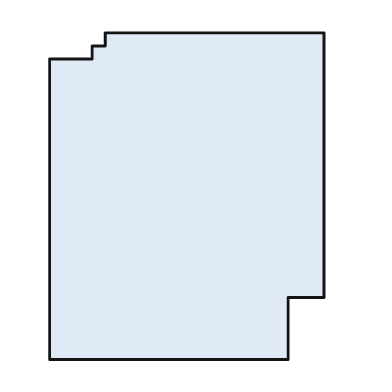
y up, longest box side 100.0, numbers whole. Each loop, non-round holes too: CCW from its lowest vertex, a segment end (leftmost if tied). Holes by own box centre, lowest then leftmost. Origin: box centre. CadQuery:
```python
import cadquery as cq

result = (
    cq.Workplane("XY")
    .moveTo(-42.0, -50.0)
    .lineTo(31.0, -50.0)
    .lineTo(31.0, -31.0)
    .lineTo(42.0, -31.0)
    .lineTo(42.0, 50.0)
    .lineTo(-25.0, 50.0)
    .lineTo(-25.0, 46.0)
    .lineTo(-29.0, 46.0)
    .lineTo(-29.0, 42.0)
    .lineTo(-42.0, 42.0)
    .close()
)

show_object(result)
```